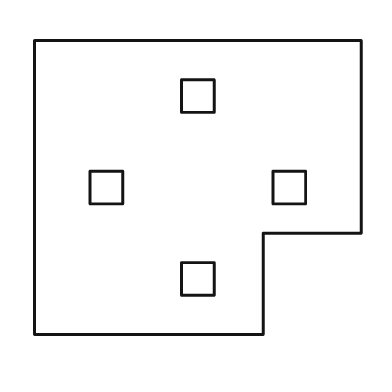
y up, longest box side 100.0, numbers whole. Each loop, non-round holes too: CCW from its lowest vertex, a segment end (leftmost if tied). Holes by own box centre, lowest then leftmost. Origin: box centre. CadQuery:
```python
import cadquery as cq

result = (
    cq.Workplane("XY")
    .moveTo(-50.0, -45.0)
    .lineTo(20.0, -45.0)
    .lineTo(20.0, -14.0)
    .lineTo(50.0, -14.0)
    .lineTo(50.0, 45.0)
    .lineTo(-50.0, 45.0)
    .close()
    .moveTo(-5.0, -33.0)
    .lineTo(5.0, -33.0)
    .lineTo(5.0, -23.0)
    .lineTo(-5.0, -23.0)
    .close()
    .moveTo(-33.0, -5.0)
    .lineTo(-23.0, -5.0)
    .lineTo(-23.0, 5.0)
    .lineTo(-33.0, 5.0)
    .close()
    .moveTo(23.0, -5.0)
    .lineTo(33.0, -5.0)
    .lineTo(33.0, 5.0)
    .lineTo(23.0, 5.0)
    .close()
    .moveTo(-5.0, 23.0)
    .lineTo(5.0, 23.0)
    .lineTo(5.0, 33.0)
    .lineTo(-5.0, 33.0)
    .close()
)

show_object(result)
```